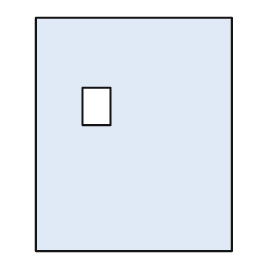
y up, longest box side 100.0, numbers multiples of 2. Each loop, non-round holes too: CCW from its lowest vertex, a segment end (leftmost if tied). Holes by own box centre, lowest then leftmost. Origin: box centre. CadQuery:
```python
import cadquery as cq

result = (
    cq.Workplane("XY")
    .moveTo(-42.0, -50.0)
    .lineTo(42.0, -50.0)
    .lineTo(42.0, 50.0)
    .lineTo(-42.0, 50.0)
    .close()
    .moveTo(-22.0, 4.0)
    .lineTo(-10.0, 4.0)
    .lineTo(-10.0, 20.0)
    .lineTo(-22.0, 20.0)
    .close()
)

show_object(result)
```